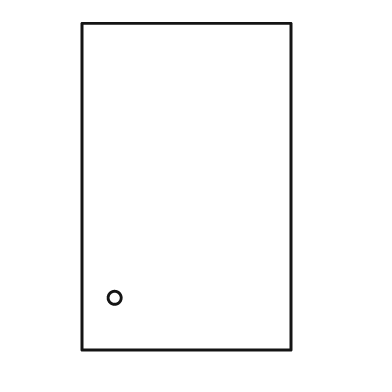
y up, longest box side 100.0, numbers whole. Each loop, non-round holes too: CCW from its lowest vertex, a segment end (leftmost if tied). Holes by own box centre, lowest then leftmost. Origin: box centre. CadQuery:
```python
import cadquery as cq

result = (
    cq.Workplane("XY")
    .moveTo(-32.0, -50.0)
    .lineTo(32.0, -50.0)
    .lineTo(32.0, 50.0)
    .lineTo(-32.0, 50.0)
    .close()
    .moveTo(-22.0, -34.0)
    .circle(2.0)
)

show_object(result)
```